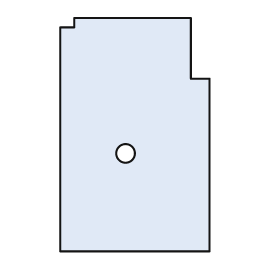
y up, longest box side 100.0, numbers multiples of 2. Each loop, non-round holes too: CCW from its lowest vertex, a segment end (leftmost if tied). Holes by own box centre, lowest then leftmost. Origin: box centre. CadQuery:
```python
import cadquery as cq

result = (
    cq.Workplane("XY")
    .moveTo(-32.0, -50.0)
    .lineTo(32.0, -50.0)
    .lineTo(32.0, 24.0)
    .lineTo(24.0, 24.0)
    .lineTo(24.0, 50.0)
    .lineTo(-26.0, 50.0)
    .lineTo(-26.0, 46.0)
    .lineTo(-32.0, 46.0)
    .close()
    .moveTo(-4.0, -8.0)
    .circle(4.0)
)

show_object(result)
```